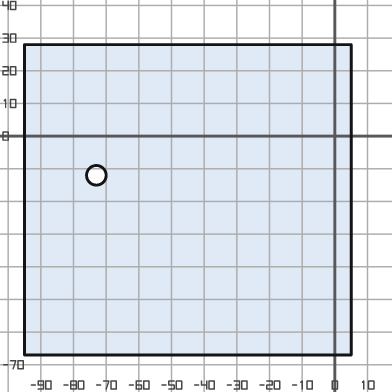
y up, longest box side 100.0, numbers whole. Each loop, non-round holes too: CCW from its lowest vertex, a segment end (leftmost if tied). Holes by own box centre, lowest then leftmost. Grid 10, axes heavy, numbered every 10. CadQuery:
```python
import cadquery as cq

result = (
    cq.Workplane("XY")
    .moveTo(-95.0, -67.0)
    .lineTo(5.0, -67.0)
    .lineTo(5.0, 28.0)
    .lineTo(-95.0, 28.0)
    .close()
    .moveTo(-73.0, -12.0)
    .circle(3.0)
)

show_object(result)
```